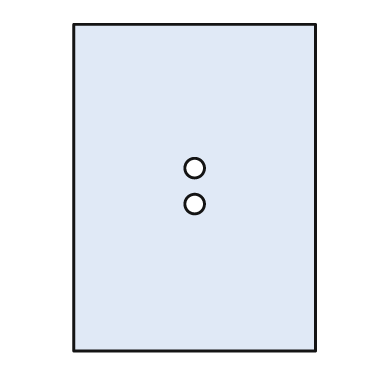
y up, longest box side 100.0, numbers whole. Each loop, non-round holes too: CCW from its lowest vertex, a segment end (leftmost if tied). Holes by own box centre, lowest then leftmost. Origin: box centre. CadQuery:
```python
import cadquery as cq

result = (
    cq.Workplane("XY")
    .moveTo(-37.0, -50.0)
    .lineTo(37.0, -50.0)
    .lineTo(37.0, 50.0)
    .lineTo(-37.0, 50.0)
    .close()
    .moveTo(0.0, -5.0)
    .circle(3.0)
    .moveTo(0.0, 6.0)
    .circle(3.0)
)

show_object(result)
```